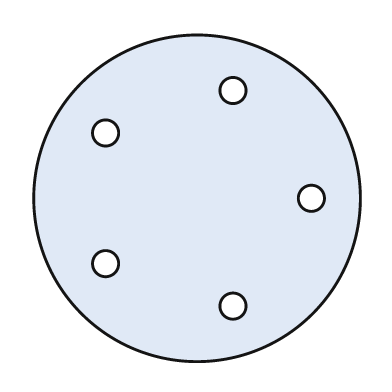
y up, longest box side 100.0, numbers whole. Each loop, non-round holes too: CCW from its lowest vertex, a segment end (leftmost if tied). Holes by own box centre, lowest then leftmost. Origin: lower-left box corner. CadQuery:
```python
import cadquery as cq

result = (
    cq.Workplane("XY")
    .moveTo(50.0, 50.0)
    .circle(50.0)
    .moveTo(61.0, 17.0)
    .circle(4.0)
    .moveTo(22.0, 30.0)
    .circle(4.0)
    .moveTo(85.0, 50.0)
    .circle(4.0)
    .moveTo(22.0, 70.0)
    .circle(4.0)
    .moveTo(61.0, 83.0)
    .circle(4.0)
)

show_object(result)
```